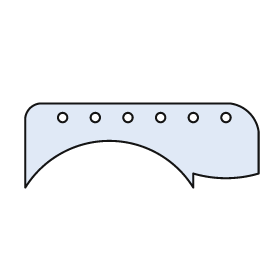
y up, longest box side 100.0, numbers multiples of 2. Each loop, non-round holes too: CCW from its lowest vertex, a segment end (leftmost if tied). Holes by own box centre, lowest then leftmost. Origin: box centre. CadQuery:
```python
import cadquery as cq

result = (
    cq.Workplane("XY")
    .moveTo(-50.0, -18.0)
    .threePointArc((-14.0, 2.0), (22.0, -18.0))
    .lineTo(22.0, -12.0)
    .threePointArc((36.0, -14.0), (50.0, -12.0))
    .lineTo(50.0, 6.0)
    .threePointArc((46.0, 14.0), (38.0, 18.0))
    .lineTo(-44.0, 18.0)
    .threePointArc((-48.0, 16.0), (-50.0, 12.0))
    .close()
    .moveTo(-34.0, 12.0)
    .circle(2.0)
    .moveTo(-20.0, 12.0)
    .circle(2.0)
    .moveTo(-6.0, 12.0)
    .circle(2.0)
    .moveTo(8.0, 12.0)
    .circle(2.0)
    .moveTo(22.0, 12.0)
    .circle(2.0)
    .moveTo(36.0, 12.0)
    .circle(2.0)
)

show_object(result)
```